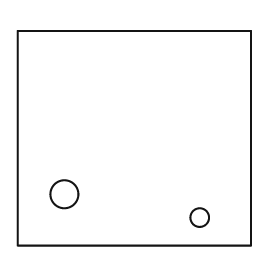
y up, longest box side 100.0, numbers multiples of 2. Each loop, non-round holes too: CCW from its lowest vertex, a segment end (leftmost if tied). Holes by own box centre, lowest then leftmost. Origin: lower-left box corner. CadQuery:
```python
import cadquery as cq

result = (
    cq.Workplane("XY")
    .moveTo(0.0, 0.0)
    .lineTo(100.0, 0.0)
    .lineTo(100.0, 92.0)
    .lineTo(0.0, 92.0)
    .close()
    .moveTo(78.0, 12.0)
    .circle(4.0)
    .moveTo(20.0, 22.0)
    .circle(6.0)
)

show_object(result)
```